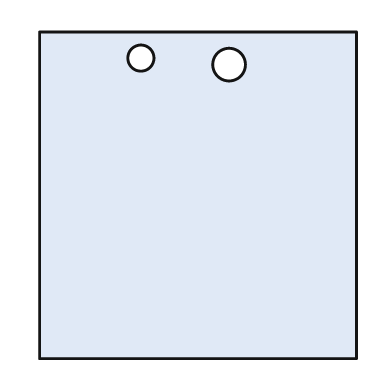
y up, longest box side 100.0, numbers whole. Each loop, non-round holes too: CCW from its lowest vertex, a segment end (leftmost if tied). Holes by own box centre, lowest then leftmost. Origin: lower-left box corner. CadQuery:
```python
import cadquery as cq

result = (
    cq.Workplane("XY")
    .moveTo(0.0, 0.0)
    .lineTo(97.0, 0.0)
    .lineTo(97.0, 100.0)
    .lineTo(0.0, 100.0)
    .close()
    .moveTo(58.0, 90.0)
    .circle(5.0)
    .moveTo(31.0, 92.0)
    .circle(4.0)
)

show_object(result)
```